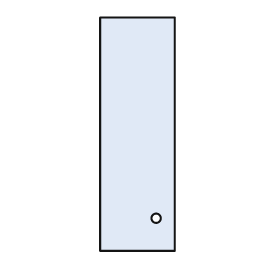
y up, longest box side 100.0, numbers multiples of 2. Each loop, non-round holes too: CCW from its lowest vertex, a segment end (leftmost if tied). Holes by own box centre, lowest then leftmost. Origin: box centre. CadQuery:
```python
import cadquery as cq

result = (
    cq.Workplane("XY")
    .moveTo(-16.0, -50.0)
    .lineTo(16.0, -50.0)
    .lineTo(16.0, 50.0)
    .lineTo(-16.0, 50.0)
    .close()
    .moveTo(8.0, -36.0)
    .circle(2.0)
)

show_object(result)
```